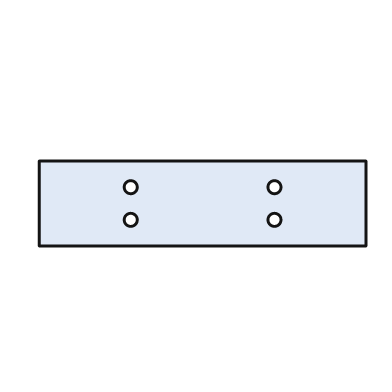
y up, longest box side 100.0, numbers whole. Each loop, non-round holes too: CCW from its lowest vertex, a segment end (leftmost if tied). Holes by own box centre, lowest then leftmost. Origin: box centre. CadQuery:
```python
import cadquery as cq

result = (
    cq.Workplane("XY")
    .moveTo(-50.0, -13.0)
    .lineTo(50.0, -13.0)
    .lineTo(50.0, 13.0)
    .lineTo(-50.0, 13.0)
    .close()
    .moveTo(-22.0, -5.0)
    .circle(2.0)
    .moveTo(22.0, -5.0)
    .circle(2.0)
    .moveTo(-22.0, 5.0)
    .circle(2.0)
    .moveTo(22.0, 5.0)
    .circle(2.0)
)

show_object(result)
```